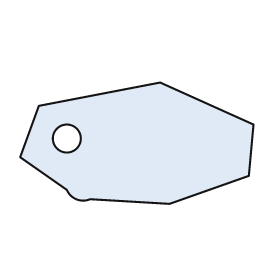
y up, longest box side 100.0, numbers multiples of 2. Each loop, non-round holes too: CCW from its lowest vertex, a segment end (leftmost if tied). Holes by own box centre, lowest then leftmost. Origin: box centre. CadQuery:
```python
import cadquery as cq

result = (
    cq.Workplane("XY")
    .moveTo(14.0, -26.0)
    .lineTo(48.0, -14.0)
    .lineTo(50.0, 8.0)
    .lineTo(10.0, 26.0)
    .lineTo(-42.0, 16.0)
    .lineTo(-50.0, -6.0)
    .lineTo(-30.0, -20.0)
    .threePointArc((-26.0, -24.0), (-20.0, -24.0))
    .close()
    .moveTo(-30.0, 2.0)
    .circle(6.0)
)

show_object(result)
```